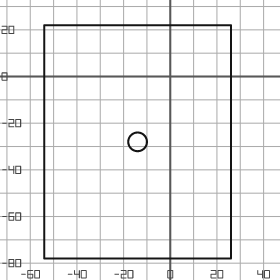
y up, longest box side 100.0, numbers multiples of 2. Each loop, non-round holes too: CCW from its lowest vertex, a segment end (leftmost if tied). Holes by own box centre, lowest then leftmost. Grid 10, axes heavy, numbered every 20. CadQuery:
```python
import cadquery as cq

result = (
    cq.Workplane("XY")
    .moveTo(-54.0, -78.0)
    .lineTo(26.0, -78.0)
    .lineTo(26.0, 22.0)
    .lineTo(-54.0, 22.0)
    .close()
    .moveTo(-14.0, -28.0)
    .circle(4.0)
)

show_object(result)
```